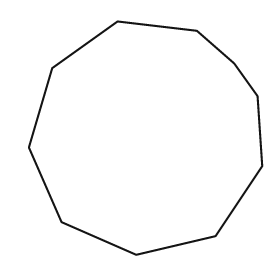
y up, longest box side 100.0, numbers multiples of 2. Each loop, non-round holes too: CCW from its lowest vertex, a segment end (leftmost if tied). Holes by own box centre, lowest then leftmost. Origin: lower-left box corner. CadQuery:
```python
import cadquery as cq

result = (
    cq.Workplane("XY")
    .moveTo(46.0, 0.0)
    .lineTo(80.0, 8.0)
    .lineTo(100.0, 38.0)
    .lineTo(98.0, 68.0)
    .lineTo(88.0, 82.0)
    .lineTo(72.0, 96.0)
    .lineTo(38.0, 100.0)
    .lineTo(10.0, 80.0)
    .lineTo(0.0, 46.0)
    .lineTo(14.0, 14.0)
    .close()
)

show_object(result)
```